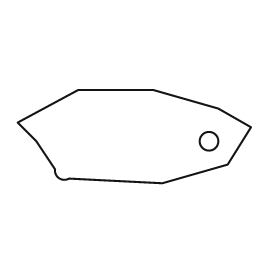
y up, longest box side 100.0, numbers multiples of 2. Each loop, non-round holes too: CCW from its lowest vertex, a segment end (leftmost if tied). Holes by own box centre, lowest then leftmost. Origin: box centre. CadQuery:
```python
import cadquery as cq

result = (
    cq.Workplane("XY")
    .moveTo(12.0, -20.0)
    .lineTo(40.0, -12.0)
    .lineTo(50.0, 4.0)
    .lineTo(36.0, 12.0)
    .lineTo(8.0, 20.0)
    .lineTo(-24.0, 20.0)
    .lineTo(-50.0, 6.0)
    .lineTo(-42.0, -2.0)
    .lineTo(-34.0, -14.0)
    .threePointArc((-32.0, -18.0), (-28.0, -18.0))
    .close()
    .moveTo(32.0, -2.0)
    .circle(4.0)
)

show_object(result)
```